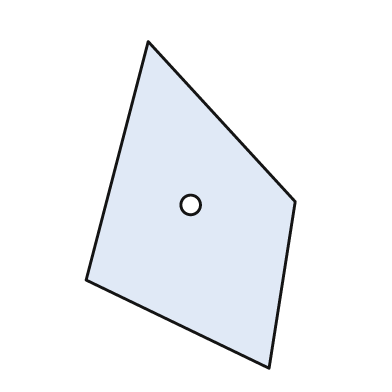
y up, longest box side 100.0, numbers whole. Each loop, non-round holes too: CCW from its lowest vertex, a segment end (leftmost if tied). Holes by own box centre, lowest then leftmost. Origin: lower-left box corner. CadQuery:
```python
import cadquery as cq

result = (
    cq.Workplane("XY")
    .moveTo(56.0, 0.0)
    .lineTo(64.0, 51.0)
    .lineTo(19.0, 100.0)
    .lineTo(0.0, 27.0)
    .close()
    .moveTo(32.0, 50.0)
    .circle(3.0)
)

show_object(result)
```